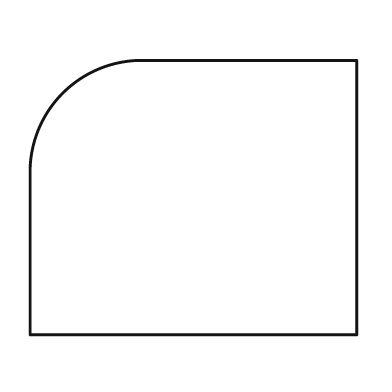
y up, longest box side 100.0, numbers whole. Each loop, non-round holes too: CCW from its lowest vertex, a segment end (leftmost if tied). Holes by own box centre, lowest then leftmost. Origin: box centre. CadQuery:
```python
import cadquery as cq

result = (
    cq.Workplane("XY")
    .moveTo(-50.0, -42.0)
    .lineTo(50.0, -42.0)
    .lineTo(50.0, 42.0)
    .lineTo(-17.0, 42.0)
    .threePointArc((-40.0, 32.0), (-50.0, 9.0))
    .close()
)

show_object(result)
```